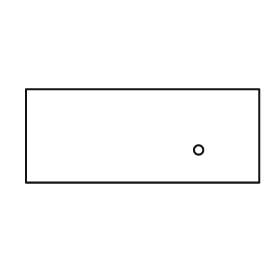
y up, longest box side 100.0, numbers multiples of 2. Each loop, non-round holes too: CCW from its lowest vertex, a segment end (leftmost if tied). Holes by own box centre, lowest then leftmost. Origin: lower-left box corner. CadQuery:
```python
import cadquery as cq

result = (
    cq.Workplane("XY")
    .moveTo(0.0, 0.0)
    .lineTo(100.0, 0.0)
    .lineTo(100.0, 40.0)
    .lineTo(0.0, 40.0)
    .close()
    .moveTo(74.0, 14.0)
    .circle(2.0)
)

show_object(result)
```